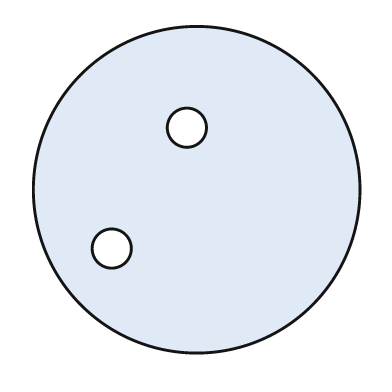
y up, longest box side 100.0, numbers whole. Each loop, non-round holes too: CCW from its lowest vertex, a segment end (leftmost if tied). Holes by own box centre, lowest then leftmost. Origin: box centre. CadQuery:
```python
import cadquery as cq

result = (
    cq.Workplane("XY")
    .moveTo(0.0, 0.0)
    .circle(50.0)
    .moveTo(-26.0, -18.0)
    .circle(6.0)
    .moveTo(-3.0, 19.0)
    .circle(6.0)
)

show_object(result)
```